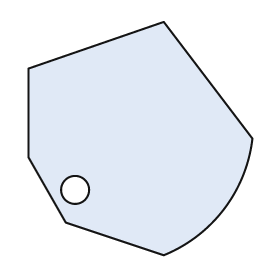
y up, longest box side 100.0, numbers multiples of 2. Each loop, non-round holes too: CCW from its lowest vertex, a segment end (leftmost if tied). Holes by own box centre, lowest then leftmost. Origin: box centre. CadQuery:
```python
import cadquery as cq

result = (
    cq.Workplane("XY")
    .moveTo(10.0, -50.0)
    .threePointArc((36.0, -30.0), (48.0, 0.0))
    .lineTo(10.0, 50.0)
    .lineTo(-48.0, 30.0)
    .lineTo(-48.0, -8.0)
    .lineTo(-32.0, -36.0)
    .close()
    .moveTo(-28.0, -22.0)
    .circle(6.0)
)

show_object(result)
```